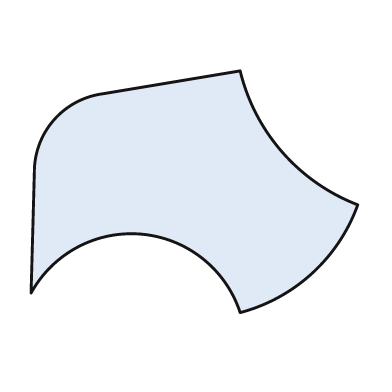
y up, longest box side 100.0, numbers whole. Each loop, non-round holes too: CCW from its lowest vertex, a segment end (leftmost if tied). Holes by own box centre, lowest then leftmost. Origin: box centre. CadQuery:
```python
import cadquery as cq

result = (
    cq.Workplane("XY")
    .moveTo(14.0, -37.0)
    .threePointArc((36.0, -25.0), (50.0, -4.0))
    .threePointArc((27.0, 12.0), (14.0, 37.0))
    .lineTo(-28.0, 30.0)
    .threePointArc((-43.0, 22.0), (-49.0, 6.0))
    .lineTo(-50.0, -31.0)
    .threePointArc((-16.0, -13.0), (14.0, -37.0))
    .close()
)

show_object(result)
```